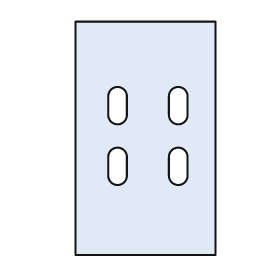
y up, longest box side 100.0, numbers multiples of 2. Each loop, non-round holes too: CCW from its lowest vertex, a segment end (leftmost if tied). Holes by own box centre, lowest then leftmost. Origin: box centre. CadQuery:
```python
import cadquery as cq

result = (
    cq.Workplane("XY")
    .moveTo(-30.0, -50.0)
    .lineTo(30.0, -50.0)
    .lineTo(30.0, 50.0)
    .lineTo(-30.0, 50.0)
    .close()
    .moveTo(-16.0, -16.0)
    .threePointArc((-12.0, -20.0), (-8.0, -16.0))
    .lineTo(-8.0, -8.0)
    .threePointArc((-12.0, -4.0), (-16.0, -8.0))
    .close()
    .moveTo(10.0, -16.0)
    .threePointArc((14.0, -20.0), (18.0, -16.0))
    .lineTo(18.0, -8.0)
    .threePointArc((14.0, -4.0), (10.0, -8.0))
    .close()
    .moveTo(-16.0, 10.0)
    .threePointArc((-12.0, 6.0), (-8.0, 10.0))
    .lineTo(-8.0, 18.0)
    .threePointArc((-12.0, 22.0), (-16.0, 18.0))
    .close()
    .moveTo(10.0, 10.0)
    .threePointArc((14.0, 6.0), (18.0, 10.0))
    .lineTo(18.0, 18.0)
    .threePointArc((14.0, 22.0), (10.0, 18.0))
    .close()
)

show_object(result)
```